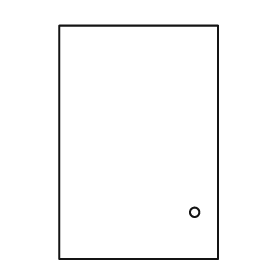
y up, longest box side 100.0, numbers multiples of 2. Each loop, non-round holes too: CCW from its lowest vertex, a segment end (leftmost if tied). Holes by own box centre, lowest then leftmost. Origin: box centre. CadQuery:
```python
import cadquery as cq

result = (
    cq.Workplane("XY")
    .moveTo(-34.0, -50.0)
    .lineTo(34.0, -50.0)
    .lineTo(34.0, 50.0)
    .lineTo(-34.0, 50.0)
    .close()
    .moveTo(24.0, -30.0)
    .circle(2.0)
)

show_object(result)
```